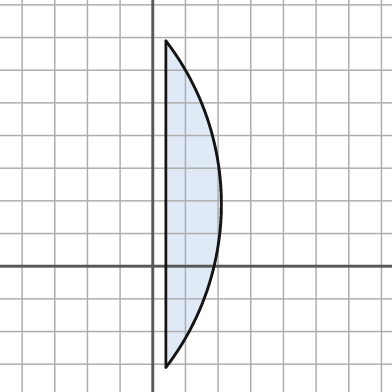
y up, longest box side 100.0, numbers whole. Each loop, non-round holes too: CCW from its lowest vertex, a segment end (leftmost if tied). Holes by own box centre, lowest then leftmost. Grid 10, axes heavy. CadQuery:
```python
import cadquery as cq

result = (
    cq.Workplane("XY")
    .moveTo(4.0, -31.0)
    .threePointArc((21.0, 19.0), (4.0, 69.0))
    .close()
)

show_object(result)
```